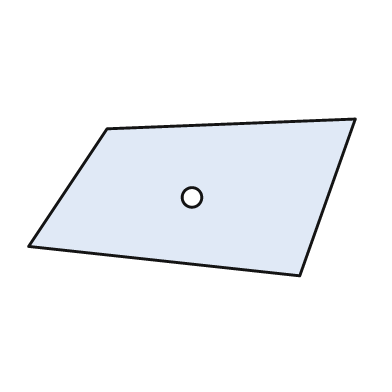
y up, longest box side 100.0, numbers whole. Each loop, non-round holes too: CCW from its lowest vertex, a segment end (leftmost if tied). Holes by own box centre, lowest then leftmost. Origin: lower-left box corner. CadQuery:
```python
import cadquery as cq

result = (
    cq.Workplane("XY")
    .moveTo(83.0, 0.0)
    .lineTo(100.0, 48.0)
    .lineTo(24.0, 45.0)
    .lineTo(0.0, 9.0)
    .close()
    .moveTo(50.0, 24.0)
    .circle(3.0)
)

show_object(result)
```